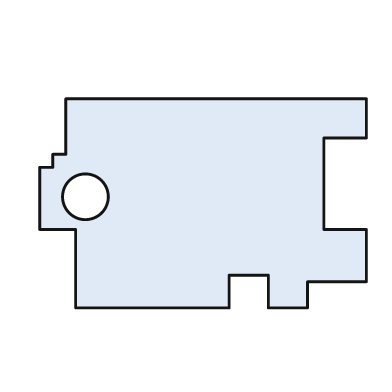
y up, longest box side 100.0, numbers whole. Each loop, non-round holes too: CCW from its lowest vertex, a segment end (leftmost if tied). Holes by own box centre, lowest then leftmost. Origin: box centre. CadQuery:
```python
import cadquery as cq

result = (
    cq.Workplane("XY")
    .moveTo(-39.0, -32.0)
    .lineTo(8.0, -32.0)
    .lineTo(8.0, -22.0)
    .lineTo(20.0, -22.0)
    .lineTo(20.0, -32.0)
    .lineTo(32.0, -32.0)
    .lineTo(32.0, -24.0)
    .lineTo(50.0, -24.0)
    .lineTo(50.0, -8.0)
    .lineTo(37.0, -8.0)
    .lineTo(37.0, 20.0)
    .lineTo(50.0, 20.0)
    .lineTo(50.0, 32.0)
    .lineTo(-42.0, 32.0)
    .lineTo(-42.0, 15.0)
    .lineTo(-46.0, 15.0)
    .lineTo(-46.0, 11.0)
    .lineTo(-50.0, 11.0)
    .lineTo(-50.0, -8.0)
    .lineTo(-39.0, -8.0)
    .close()
    .moveTo(-36.0, 2.0)
    .circle(7.0)
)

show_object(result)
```